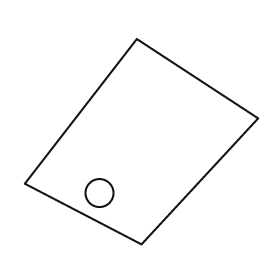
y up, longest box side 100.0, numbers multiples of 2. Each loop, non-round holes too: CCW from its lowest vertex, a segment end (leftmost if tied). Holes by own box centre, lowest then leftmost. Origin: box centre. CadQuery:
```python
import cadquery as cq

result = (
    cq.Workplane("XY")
    .moveTo(0.0, -44.0)
    .lineTo(50.0, 10.0)
    .lineTo(-2.0, 44.0)
    .lineTo(-50.0, -18.0)
    .close()
    .moveTo(-18.0, -22.0)
    .circle(6.0)
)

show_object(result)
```